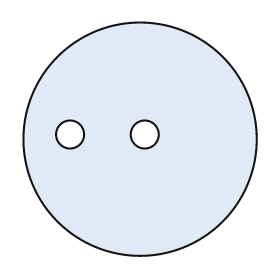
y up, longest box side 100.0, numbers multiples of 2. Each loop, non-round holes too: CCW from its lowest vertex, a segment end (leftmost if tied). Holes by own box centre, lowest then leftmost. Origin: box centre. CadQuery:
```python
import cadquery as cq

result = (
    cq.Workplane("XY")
    .moveTo(0.0, 0.0)
    .circle(50.0)
    .moveTo(-30.0, 2.0)
    .circle(6.0)
    .moveTo(2.0, 2.0)
    .circle(6.0)
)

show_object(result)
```